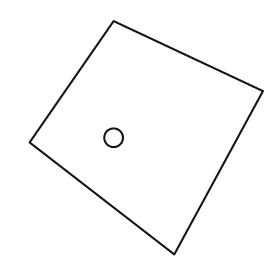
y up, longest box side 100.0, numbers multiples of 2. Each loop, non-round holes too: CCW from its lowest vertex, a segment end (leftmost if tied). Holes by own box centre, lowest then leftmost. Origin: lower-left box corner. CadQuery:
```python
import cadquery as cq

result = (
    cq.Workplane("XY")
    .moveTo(62.0, 0.0)
    .lineTo(100.0, 70.0)
    .lineTo(36.0, 100.0)
    .lineTo(0.0, 48.0)
    .close()
    .moveTo(36.0, 50.0)
    .circle(4.0)
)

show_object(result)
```